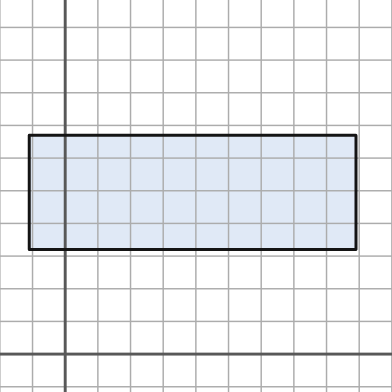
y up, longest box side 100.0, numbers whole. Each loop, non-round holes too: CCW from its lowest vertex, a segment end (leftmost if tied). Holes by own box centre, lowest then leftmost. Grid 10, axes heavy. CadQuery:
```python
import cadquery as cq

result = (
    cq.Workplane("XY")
    .moveTo(-11.0, 32.0)
    .lineTo(89.0, 32.0)
    .lineTo(89.0, 67.0)
    .lineTo(-11.0, 67.0)
    .close()
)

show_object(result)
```